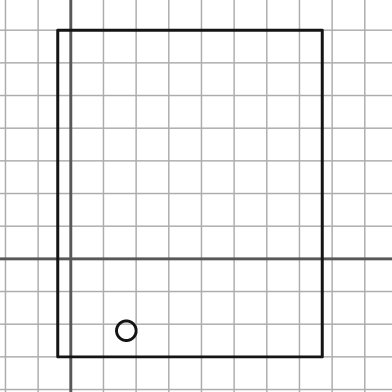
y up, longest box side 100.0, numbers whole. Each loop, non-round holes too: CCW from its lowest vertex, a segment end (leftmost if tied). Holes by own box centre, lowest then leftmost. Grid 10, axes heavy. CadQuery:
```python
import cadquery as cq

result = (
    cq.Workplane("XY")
    .moveTo(-4.0, -30.0)
    .lineTo(77.0, -30.0)
    .lineTo(77.0, 70.0)
    .lineTo(-4.0, 70.0)
    .close()
    .moveTo(17.0, -22.0)
    .circle(3.0)
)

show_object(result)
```